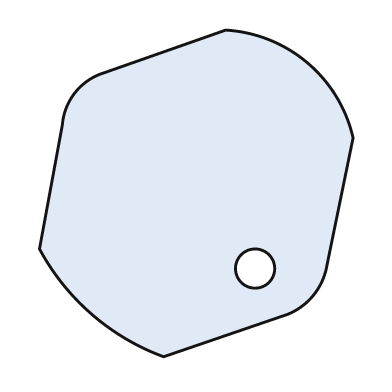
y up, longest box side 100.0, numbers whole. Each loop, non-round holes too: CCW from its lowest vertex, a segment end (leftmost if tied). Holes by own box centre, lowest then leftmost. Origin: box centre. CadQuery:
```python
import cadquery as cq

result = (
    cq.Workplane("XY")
    .moveTo(-10.0, -50.0)
    .lineTo(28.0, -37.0)
    .threePointArc((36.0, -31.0), (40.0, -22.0))
    .lineTo(48.0, 17.0)
    .threePointArc((34.0, 40.0), (9.0, 50.0))
    .lineTo(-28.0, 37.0)
    .threePointArc((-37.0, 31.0), (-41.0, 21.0))
    .lineTo(-48.0, -17.0)
    .threePointArc((-32.0, -37.0), (-10.0, -50.0))
    .close()
    .moveTo(18.0, -23.0)
    .circle(6.0)
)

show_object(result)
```